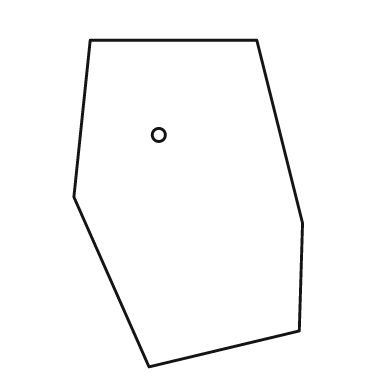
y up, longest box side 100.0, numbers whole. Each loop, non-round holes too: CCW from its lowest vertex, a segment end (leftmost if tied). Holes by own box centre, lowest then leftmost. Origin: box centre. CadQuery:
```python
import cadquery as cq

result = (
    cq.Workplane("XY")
    .moveTo(-12.0, -50.0)
    .lineTo(34.0, -39.0)
    .lineTo(35.0, -6.0)
    .lineTo(21.0, 50.0)
    .lineTo(-30.0, 50.0)
    .lineTo(-35.0, 2.0)
    .close()
    .moveTo(-9.0, 21.0)
    .circle(2.0)
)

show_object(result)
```